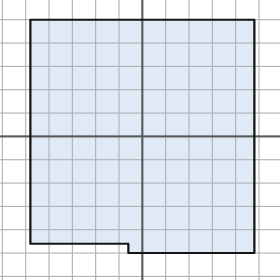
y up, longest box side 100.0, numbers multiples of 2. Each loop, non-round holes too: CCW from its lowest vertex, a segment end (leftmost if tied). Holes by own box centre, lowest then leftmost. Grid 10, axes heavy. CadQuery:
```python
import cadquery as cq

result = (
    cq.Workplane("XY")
    .moveTo(-6.0, -50.0)
    .lineTo(48.0, -50.0)
    .lineTo(48.0, 50.0)
    .lineTo(-48.0, 50.0)
    .lineTo(-48.0, -46.0)
    .lineTo(-6.0, -46.0)
    .close()
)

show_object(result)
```